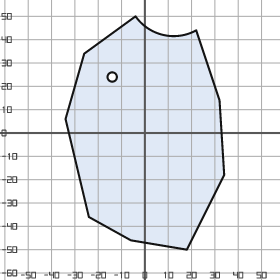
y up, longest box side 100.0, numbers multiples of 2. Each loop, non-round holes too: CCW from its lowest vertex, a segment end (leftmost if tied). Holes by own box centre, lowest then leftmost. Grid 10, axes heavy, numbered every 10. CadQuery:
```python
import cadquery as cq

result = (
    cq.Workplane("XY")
    .moveTo(18.0, -50.0)
    .lineTo(34.0, -18.0)
    .lineTo(32.0, 14.0)
    .lineTo(22.0, 44.0)
    .threePointArc((8.0, 42.0), (-4.0, 50.0))
    .lineTo(-26.0, 34.0)
    .lineTo(-34.0, 6.0)
    .lineTo(-24.0, -36.0)
    .lineTo(-6.0, -46.0)
    .close()
    .moveTo(-14.0, 24.0)
    .circle(2.0)
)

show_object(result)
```